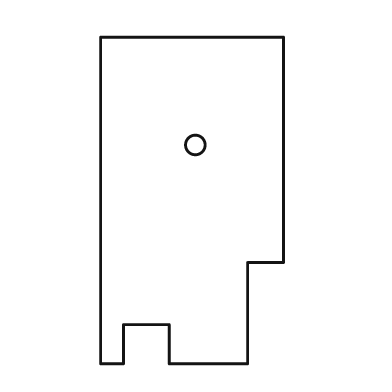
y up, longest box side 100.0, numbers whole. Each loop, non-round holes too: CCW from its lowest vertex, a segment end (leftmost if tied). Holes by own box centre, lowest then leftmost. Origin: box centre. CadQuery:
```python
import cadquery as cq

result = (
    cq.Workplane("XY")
    .moveTo(-28.0, -50.0)
    .lineTo(-21.0, -50.0)
    .lineTo(-21.0, -38.0)
    .lineTo(-7.0, -38.0)
    .lineTo(-7.0, -50.0)
    .lineTo(17.0, -50.0)
    .lineTo(17.0, -19.0)
    .lineTo(28.0, -19.0)
    .lineTo(28.0, 50.0)
    .lineTo(-28.0, 50.0)
    .close()
    .moveTo(1.0, 17.0)
    .circle(3.0)
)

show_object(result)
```